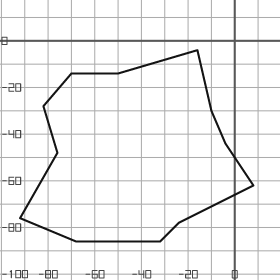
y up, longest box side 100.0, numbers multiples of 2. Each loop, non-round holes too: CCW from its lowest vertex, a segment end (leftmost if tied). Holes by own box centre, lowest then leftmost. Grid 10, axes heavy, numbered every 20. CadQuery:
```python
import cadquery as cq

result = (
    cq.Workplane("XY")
    .moveTo(-68.0, -86.0)
    .lineTo(-32.0, -86.0)
    .lineTo(-24.0, -78.0)
    .lineTo(8.0, -62.0)
    .lineTo(-4.0, -44.0)
    .lineTo(-10.0, -30.0)
    .lineTo(-16.0, -4.0)
    .lineTo(-50.0, -14.0)
    .lineTo(-70.0, -14.0)
    .lineTo(-82.0, -28.0)
    .lineTo(-76.0, -48.0)
    .lineTo(-92.0, -76.0)
    .close()
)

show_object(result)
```